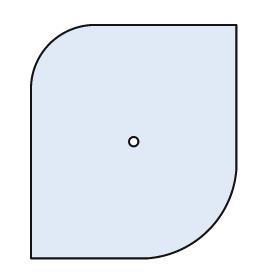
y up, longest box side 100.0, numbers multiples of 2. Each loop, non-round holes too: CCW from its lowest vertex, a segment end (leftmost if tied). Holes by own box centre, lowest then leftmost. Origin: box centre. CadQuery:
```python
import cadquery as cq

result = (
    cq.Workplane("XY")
    .moveTo(-44.0, -50.0)
    .lineTo(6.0, -50.0)
    .threePointArc((32.0, -38.0), (44.0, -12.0))
    .lineTo(44.0, 50.0)
    .lineTo(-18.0, 50.0)
    .threePointArc((-36.0, 42.0), (-44.0, 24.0))
    .close()
    .moveTo(0.0, 0.0)
    .circle(2.0)
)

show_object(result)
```